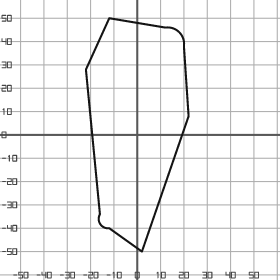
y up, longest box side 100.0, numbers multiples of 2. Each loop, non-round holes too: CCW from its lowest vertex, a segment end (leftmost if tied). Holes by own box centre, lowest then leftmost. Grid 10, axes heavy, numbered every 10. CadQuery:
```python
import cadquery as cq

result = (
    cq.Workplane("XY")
    .moveTo(2.0, -50.0)
    .lineTo(22.0, 8.0)
    .lineTo(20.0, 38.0)
    .threePointArc((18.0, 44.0), (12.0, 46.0))
    .lineTo(-12.0, 50.0)
    .lineTo(-22.0, 28.0)
    .lineTo(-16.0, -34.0)
    .threePointArc((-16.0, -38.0), (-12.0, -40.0))
    .close()
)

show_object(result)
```